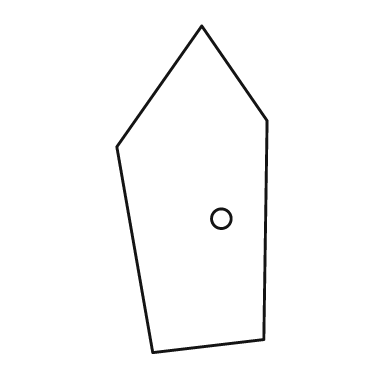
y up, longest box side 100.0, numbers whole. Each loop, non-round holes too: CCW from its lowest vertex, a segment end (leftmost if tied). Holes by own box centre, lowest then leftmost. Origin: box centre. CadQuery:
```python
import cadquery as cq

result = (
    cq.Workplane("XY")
    .moveTo(-12.0, -50.0)
    .lineTo(22.0, -46.0)
    .lineTo(23.0, 21.0)
    .lineTo(3.0, 50.0)
    .lineTo(-23.0, 13.0)
    .close()
    .moveTo(9.0, -9.0)
    .circle(3.0)
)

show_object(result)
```